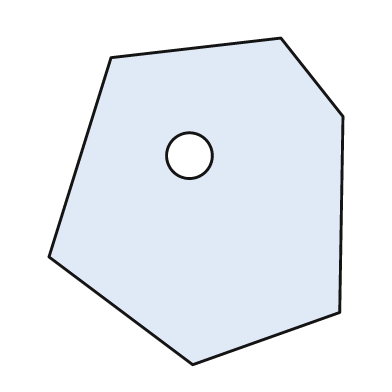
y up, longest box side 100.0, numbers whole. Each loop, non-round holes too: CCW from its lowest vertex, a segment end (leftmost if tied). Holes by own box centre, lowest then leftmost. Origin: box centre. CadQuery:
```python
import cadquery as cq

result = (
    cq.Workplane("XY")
    .moveTo(-1.0, -50.0)
    .lineTo(44.0, -34.0)
    .lineTo(45.0, 26.0)
    .lineTo(26.0, 50.0)
    .lineTo(-26.0, 44.0)
    .lineTo(-45.0, -17.0)
    .close()
    .moveTo(-2.0, 14.0)
    .circle(7.0)
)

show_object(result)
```